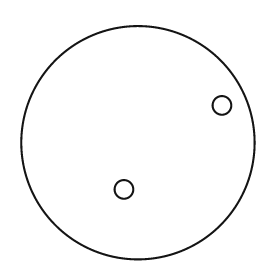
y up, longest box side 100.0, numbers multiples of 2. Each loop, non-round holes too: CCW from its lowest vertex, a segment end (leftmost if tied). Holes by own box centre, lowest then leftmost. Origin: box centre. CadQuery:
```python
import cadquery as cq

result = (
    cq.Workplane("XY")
    .moveTo(0.0, 0.0)
    .circle(50.0)
    .moveTo(-6.0, -20.0)
    .circle(4.0)
    .moveTo(36.0, 16.0)
    .circle(4.0)
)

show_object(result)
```